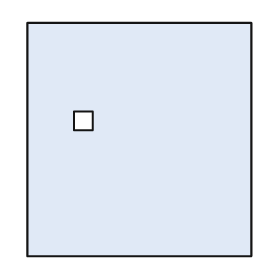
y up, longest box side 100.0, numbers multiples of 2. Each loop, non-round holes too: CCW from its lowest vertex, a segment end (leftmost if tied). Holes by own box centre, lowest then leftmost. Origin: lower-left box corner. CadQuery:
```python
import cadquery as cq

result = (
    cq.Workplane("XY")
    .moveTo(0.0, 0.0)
    .lineTo(96.0, 0.0)
    .lineTo(96.0, 100.0)
    .lineTo(0.0, 100.0)
    .close()
    .moveTo(20.0, 54.0)
    .lineTo(28.0, 54.0)
    .lineTo(28.0, 62.0)
    .lineTo(20.0, 62.0)
    .close()
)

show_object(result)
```